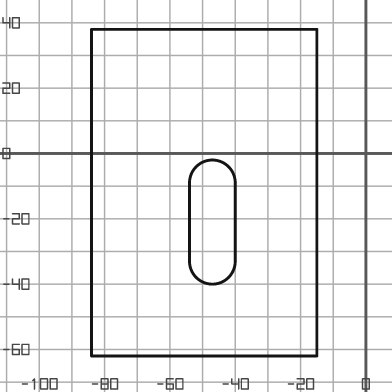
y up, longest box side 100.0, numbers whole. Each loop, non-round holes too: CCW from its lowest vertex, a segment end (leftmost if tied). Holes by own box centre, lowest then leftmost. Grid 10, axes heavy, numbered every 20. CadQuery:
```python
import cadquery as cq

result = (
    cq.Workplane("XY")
    .moveTo(-84.0, -62.0)
    .lineTo(-15.0, -62.0)
    .lineTo(-15.0, 38.0)
    .lineTo(-84.0, 38.0)
    .close()
    .moveTo(-54.0, -33.0)
    .threePointArc((-47.0, -40.0), (-40.0, -33.0))
    .lineTo(-40.0, -9.0)
    .threePointArc((-47.0, -2.0), (-54.0, -9.0))
    .close()
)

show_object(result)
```